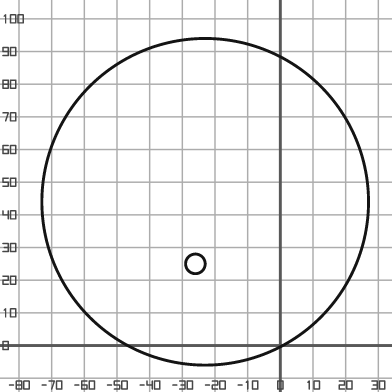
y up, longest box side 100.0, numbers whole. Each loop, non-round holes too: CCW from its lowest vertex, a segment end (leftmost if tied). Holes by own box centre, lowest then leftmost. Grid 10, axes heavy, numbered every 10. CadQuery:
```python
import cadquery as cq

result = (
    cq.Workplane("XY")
    .moveTo(-23.0, 44.0)
    .circle(50.0)
    .moveTo(-26.0, 25.0)
    .circle(3.0)
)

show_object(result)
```